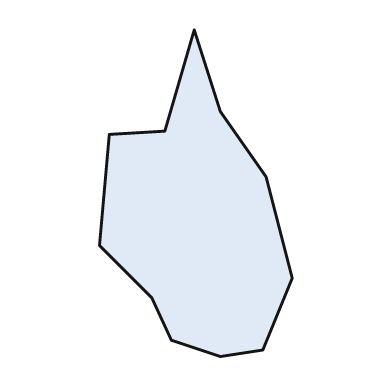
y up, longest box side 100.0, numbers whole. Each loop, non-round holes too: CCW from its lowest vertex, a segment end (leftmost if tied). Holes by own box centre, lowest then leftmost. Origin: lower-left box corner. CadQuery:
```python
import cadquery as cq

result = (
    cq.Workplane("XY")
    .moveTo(37.0, 0.0)
    .lineTo(50.0, 2.0)
    .lineTo(59.0, 24.0)
    .lineTo(51.0, 55.0)
    .lineTo(37.0, 75.0)
    .lineTo(29.0, 100.0)
    .lineTo(20.0, 69.0)
    .lineTo(3.0, 68.0)
    .lineTo(0.0, 34.0)
    .lineTo(16.0, 18.0)
    .lineTo(22.0, 5.0)
    .close()
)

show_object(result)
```